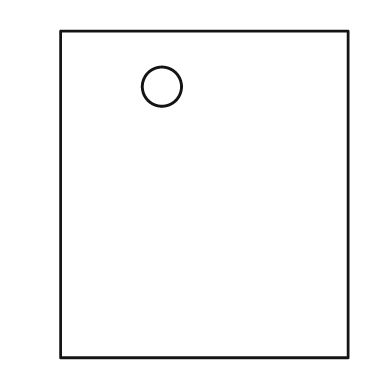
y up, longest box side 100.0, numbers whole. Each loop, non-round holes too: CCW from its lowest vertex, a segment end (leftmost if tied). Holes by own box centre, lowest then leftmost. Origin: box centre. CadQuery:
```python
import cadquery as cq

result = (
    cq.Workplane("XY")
    .moveTo(-44.0, -50.0)
    .lineTo(44.0, -50.0)
    .lineTo(44.0, 50.0)
    .lineTo(-44.0, 50.0)
    .close()
    .moveTo(-13.0, 33.0)
    .circle(6.0)
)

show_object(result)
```